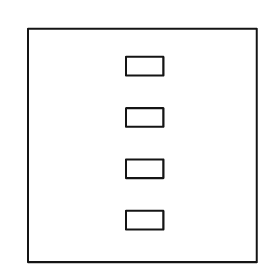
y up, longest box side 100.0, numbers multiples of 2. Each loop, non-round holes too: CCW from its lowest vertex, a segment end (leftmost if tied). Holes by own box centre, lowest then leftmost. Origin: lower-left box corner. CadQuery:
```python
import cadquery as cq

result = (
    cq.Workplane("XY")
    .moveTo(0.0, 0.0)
    .lineTo(98.0, 0.0)
    .lineTo(98.0, 100.0)
    .lineTo(0.0, 100.0)
    .close()
    .moveTo(42.0, 14.0)
    .lineTo(58.0, 14.0)
    .lineTo(58.0, 22.0)
    .lineTo(42.0, 22.0)
    .close()
    .moveTo(42.0, 36.0)
    .lineTo(58.0, 36.0)
    .lineTo(58.0, 44.0)
    .lineTo(42.0, 44.0)
    .close()
    .moveTo(42.0, 58.0)
    .lineTo(58.0, 58.0)
    .lineTo(58.0, 66.0)
    .lineTo(42.0, 66.0)
    .close()
    .moveTo(42.0, 80.0)
    .lineTo(58.0, 80.0)
    .lineTo(58.0, 88.0)
    .lineTo(42.0, 88.0)
    .close()
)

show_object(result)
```